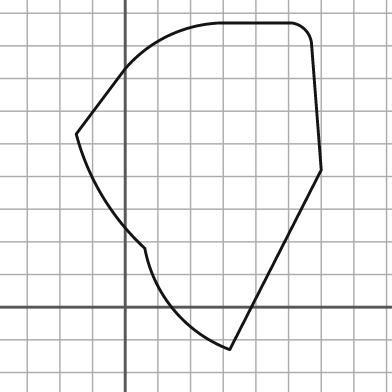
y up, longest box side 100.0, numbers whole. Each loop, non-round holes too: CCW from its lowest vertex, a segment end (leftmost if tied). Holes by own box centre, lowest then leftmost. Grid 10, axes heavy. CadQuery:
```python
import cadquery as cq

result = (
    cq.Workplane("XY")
    .moveTo(32.0, -13.0)
    .lineTo(60.0, 42.0)
    .lineTo(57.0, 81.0)
    .threePointArc((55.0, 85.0), (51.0, 87.0))
    .lineTo(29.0, 87.0)
    .threePointArc((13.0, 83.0), (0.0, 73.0))
    .lineTo(-15.0, 53.0)
    .threePointArc((-7.0, 34.0), (6.0, 18.0))
    .threePointArc((15.0, -1.0), (32.0, -13.0))
    .close()
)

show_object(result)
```